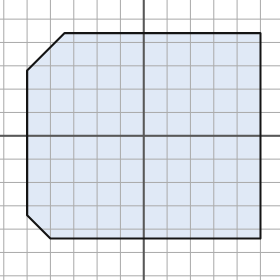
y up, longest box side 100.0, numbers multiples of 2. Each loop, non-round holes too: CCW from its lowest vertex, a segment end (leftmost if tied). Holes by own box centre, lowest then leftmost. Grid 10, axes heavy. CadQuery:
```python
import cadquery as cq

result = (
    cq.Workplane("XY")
    .moveTo(-40.0, -44.0)
    .lineTo(50.0, -44.0)
    .lineTo(50.0, 44.0)
    .lineTo(-34.0, 44.0)
    .lineTo(-50.0, 28.0)
    .lineTo(-50.0, -34.0)
    .close()
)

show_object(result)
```